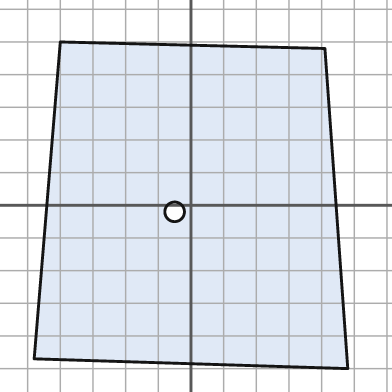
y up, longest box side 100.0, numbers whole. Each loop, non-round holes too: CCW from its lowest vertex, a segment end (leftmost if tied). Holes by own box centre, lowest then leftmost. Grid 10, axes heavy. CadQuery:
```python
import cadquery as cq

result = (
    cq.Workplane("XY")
    .moveTo(48.0, -50.0)
    .lineTo(41.0, 48.0)
    .lineTo(-40.0, 50.0)
    .lineTo(-48.0, -47.0)
    .close()
    .moveTo(-5.0, -2.0)
    .circle(3.0)
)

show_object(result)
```